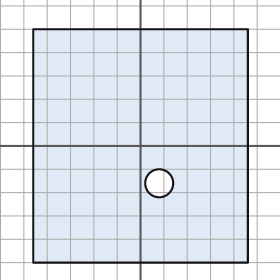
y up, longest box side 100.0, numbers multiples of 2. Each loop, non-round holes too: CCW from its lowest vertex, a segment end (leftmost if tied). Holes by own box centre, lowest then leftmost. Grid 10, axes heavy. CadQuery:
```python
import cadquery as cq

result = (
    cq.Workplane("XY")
    .moveTo(-46.0, -50.0)
    .lineTo(46.0, -50.0)
    .lineTo(46.0, 50.0)
    .lineTo(-46.0, 50.0)
    .close()
    .moveTo(8.0, -16.0)
    .circle(6.0)
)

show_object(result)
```